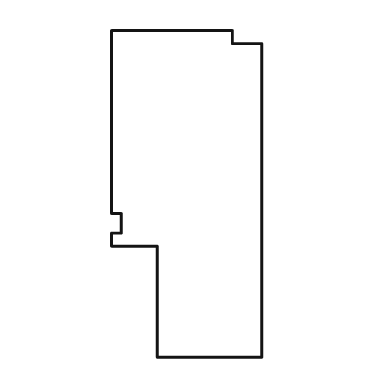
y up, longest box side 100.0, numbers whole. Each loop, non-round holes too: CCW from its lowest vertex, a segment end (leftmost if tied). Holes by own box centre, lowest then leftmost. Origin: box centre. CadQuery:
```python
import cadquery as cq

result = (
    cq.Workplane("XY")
    .moveTo(-9.0, -50.0)
    .lineTo(23.0, -50.0)
    .lineTo(23.0, 46.0)
    .lineTo(14.0, 46.0)
    .lineTo(14.0, 50.0)
    .lineTo(-23.0, 50.0)
    .lineTo(-23.0, -6.0)
    .lineTo(-20.0, -6.0)
    .lineTo(-20.0, -12.0)
    .lineTo(-23.0, -12.0)
    .lineTo(-23.0, -16.0)
    .lineTo(-9.0, -16.0)
    .close()
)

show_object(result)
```